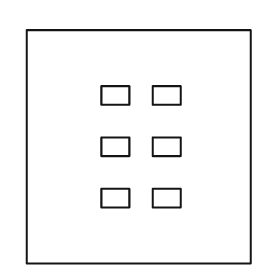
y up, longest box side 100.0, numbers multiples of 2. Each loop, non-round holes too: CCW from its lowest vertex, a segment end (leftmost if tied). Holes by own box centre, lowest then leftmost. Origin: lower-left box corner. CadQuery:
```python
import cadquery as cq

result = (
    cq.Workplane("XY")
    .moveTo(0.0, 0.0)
    .lineTo(96.0, 0.0)
    .lineTo(96.0, 100.0)
    .lineTo(0.0, 100.0)
    .close()
    .moveTo(32.0, 24.0)
    .lineTo(44.0, 24.0)
    .lineTo(44.0, 32.0)
    .lineTo(32.0, 32.0)
    .close()
    .moveTo(54.0, 24.0)
    .lineTo(66.0, 24.0)
    .lineTo(66.0, 32.0)
    .lineTo(54.0, 32.0)
    .close()
    .moveTo(32.0, 46.0)
    .lineTo(44.0, 46.0)
    .lineTo(44.0, 54.0)
    .lineTo(32.0, 54.0)
    .close()
    .moveTo(54.0, 46.0)
    .lineTo(66.0, 46.0)
    .lineTo(66.0, 54.0)
    .lineTo(54.0, 54.0)
    .close()
    .moveTo(32.0, 68.0)
    .lineTo(44.0, 68.0)
    .lineTo(44.0, 76.0)
    .lineTo(32.0, 76.0)
    .close()
    .moveTo(54.0, 68.0)
    .lineTo(66.0, 68.0)
    .lineTo(66.0, 76.0)
    .lineTo(54.0, 76.0)
    .close()
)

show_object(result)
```